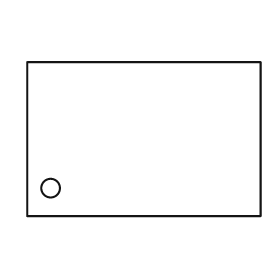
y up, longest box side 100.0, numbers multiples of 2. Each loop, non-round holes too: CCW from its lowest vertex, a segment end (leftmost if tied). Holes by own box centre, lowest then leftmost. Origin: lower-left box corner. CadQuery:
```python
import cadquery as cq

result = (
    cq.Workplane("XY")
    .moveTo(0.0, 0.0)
    .lineTo(100.0, 0.0)
    .lineTo(100.0, 66.0)
    .lineTo(0.0, 66.0)
    .close()
    .moveTo(10.0, 12.0)
    .circle(4.0)
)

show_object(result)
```